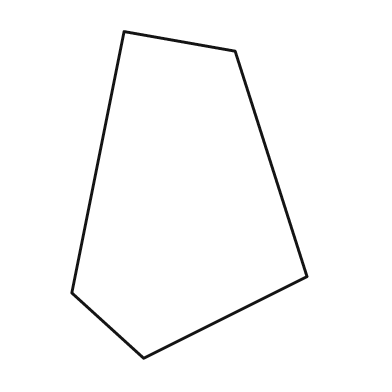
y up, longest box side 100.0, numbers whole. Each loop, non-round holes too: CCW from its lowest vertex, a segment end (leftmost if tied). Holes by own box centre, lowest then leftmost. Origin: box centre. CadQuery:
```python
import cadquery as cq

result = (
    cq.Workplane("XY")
    .moveTo(-14.0, -50.0)
    .lineTo(36.0, -25.0)
    .lineTo(14.0, 44.0)
    .lineTo(-20.0, 50.0)
    .lineTo(-36.0, -30.0)
    .close()
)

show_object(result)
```